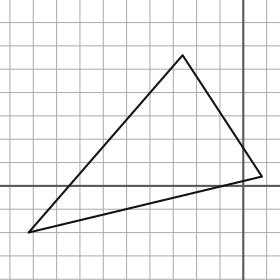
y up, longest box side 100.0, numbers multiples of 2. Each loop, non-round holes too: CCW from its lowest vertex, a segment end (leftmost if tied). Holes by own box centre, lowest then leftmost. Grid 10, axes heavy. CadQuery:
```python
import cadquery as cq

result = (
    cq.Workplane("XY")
    .moveTo(-92.0, -20.0)
    .lineTo(8.0, 4.0)
    .lineTo(-26.0, 56.0)
    .close()
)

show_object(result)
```